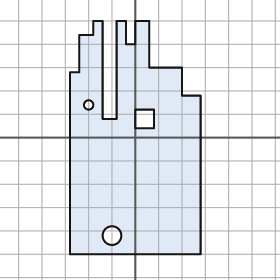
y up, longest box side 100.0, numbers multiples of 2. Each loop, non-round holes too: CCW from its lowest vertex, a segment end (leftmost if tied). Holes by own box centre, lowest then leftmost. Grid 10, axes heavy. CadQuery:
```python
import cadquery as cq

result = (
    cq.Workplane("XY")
    .moveTo(-28.0, -50.0)
    .lineTo(28.0, -50.0)
    .lineTo(28.0, 18.0)
    .lineTo(20.0, 18.0)
    .lineTo(20.0, 30.0)
    .lineTo(6.0, 30.0)
    .lineTo(6.0, 50.0)
    .lineTo(0.0, 50.0)
    .lineTo(0.0, 40.0)
    .lineTo(-4.0, 40.0)
    .lineTo(-4.0, 50.0)
    .lineTo(-8.0, 50.0)
    .lineTo(-8.0, 8.0)
    .lineTo(-14.0, 8.0)
    .lineTo(-14.0, 50.0)
    .lineTo(-18.0, 50.0)
    .lineTo(-18.0, 44.0)
    .lineTo(-24.0, 44.0)
    .lineTo(-24.0, 28.0)
    .lineTo(-28.0, 28.0)
    .close()
    .moveTo(-10.0, -42.0)
    .circle(4.0)
    .moveTo(0.0, 4.0)
    .lineTo(8.0, 4.0)
    .lineTo(8.0, 12.0)
    .lineTo(0.0, 12.0)
    .close()
    .moveTo(-20.0, 14.0)
    .circle(2.0)
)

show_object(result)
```